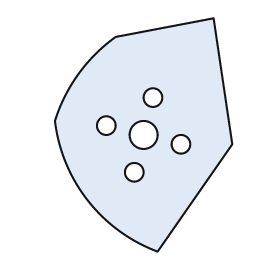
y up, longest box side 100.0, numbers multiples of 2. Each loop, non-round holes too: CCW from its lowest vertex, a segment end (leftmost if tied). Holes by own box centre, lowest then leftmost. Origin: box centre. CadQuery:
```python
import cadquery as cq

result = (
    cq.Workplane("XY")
    .moveTo(6.0, -50.0)
    .lineTo(38.0, -4.0)
    .lineTo(30.0, 50.0)
    .lineTo(-12.0, 42.0)
    .threePointArc((-28.0, 26.0), (-38.0, 6.0))
    .threePointArc((-24.0, -28.0), (6.0, -50.0))
    .close()
    .moveTo(-4.0, -16.0)
    .circle(4.0)
    .moveTo(16.0, -4.0)
    .circle(4.0)
    .moveTo(0.0, 0.0)
    .circle(6.0)
    .moveTo(-16.0, 4.0)
    .circle(4.0)
    .moveTo(4.0, 16.0)
    .circle(4.0)
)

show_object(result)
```